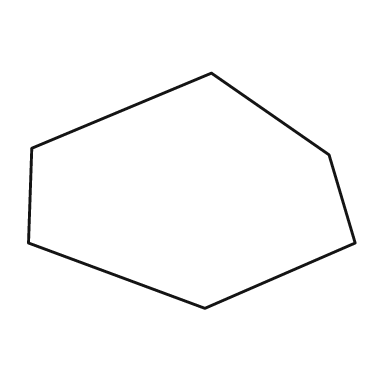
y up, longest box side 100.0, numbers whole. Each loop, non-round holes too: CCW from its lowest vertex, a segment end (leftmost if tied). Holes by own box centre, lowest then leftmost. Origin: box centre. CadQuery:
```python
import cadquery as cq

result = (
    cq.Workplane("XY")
    .moveTo(4.0, -36.0)
    .lineTo(50.0, -16.0)
    .lineTo(42.0, 11.0)
    .lineTo(6.0, 36.0)
    .lineTo(-49.0, 13.0)
    .lineTo(-50.0, -16.0)
    .close()
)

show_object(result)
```